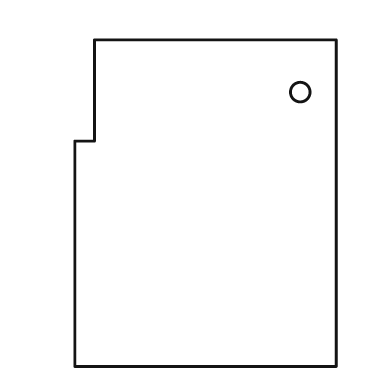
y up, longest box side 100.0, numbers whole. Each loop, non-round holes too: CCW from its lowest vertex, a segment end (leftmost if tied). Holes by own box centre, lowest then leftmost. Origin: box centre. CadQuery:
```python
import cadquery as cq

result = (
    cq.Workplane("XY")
    .moveTo(-40.0, -50.0)
    .lineTo(40.0, -50.0)
    .lineTo(40.0, 50.0)
    .lineTo(-34.0, 50.0)
    .lineTo(-34.0, 19.0)
    .lineTo(-40.0, 19.0)
    .close()
    .moveTo(29.0, 34.0)
    .circle(3.0)
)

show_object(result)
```